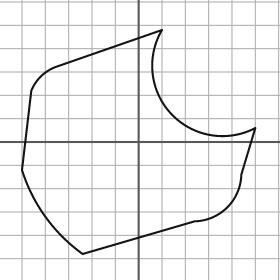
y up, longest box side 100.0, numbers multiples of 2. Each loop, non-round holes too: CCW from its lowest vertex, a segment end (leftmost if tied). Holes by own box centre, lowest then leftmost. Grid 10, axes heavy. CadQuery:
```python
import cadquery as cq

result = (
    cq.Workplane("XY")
    .moveTo(-24.0, -48.0)
    .lineTo(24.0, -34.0)
    .threePointArc((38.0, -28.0), (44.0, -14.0))
    .lineTo(50.0, 6.0)
    .threePointArc((14.0, 12.0), (10.0, 48.0))
    .lineTo(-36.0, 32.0)
    .threePointArc((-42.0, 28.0), (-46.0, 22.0))
    .lineTo(-50.0, -12.0)
    .threePointArc((-40.0, -32.0), (-24.0, -48.0))
    .close()
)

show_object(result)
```